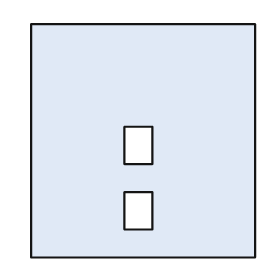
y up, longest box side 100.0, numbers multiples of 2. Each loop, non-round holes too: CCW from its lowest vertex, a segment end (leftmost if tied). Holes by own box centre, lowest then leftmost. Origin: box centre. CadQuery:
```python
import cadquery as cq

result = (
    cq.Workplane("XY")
    .moveTo(-48.0, -50.0)
    .lineTo(48.0, -50.0)
    .lineTo(48.0, 50.0)
    .lineTo(-48.0, 50.0)
    .close()
    .moveTo(-8.0, -38.0)
    .lineTo(4.0, -38.0)
    .lineTo(4.0, -22.0)
    .lineTo(-8.0, -22.0)
    .close()
    .moveTo(-8.0, -10.0)
    .lineTo(4.0, -10.0)
    .lineTo(4.0, 6.0)
    .lineTo(-8.0, 6.0)
    .close()
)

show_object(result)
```